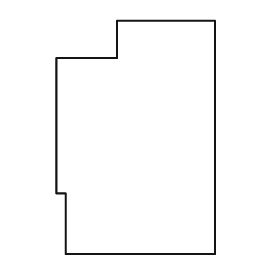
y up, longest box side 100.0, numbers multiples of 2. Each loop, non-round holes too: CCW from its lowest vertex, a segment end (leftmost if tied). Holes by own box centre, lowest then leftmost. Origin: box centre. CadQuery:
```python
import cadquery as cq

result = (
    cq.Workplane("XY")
    .moveTo(-30.0, -50.0)
    .lineTo(34.0, -50.0)
    .lineTo(34.0, 50.0)
    .lineTo(-8.0, 50.0)
    .lineTo(-8.0, 34.0)
    .lineTo(-34.0, 34.0)
    .lineTo(-34.0, -24.0)
    .lineTo(-30.0, -24.0)
    .close()
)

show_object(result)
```